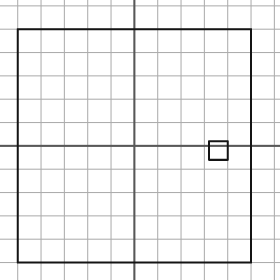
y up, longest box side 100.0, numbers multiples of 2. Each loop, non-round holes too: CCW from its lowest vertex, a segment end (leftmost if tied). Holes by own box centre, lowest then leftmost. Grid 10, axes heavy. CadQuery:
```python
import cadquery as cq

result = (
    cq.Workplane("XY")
    .moveTo(-50.0, -50.0)
    .lineTo(50.0, -50.0)
    .lineTo(50.0, 50.0)
    .lineTo(-50.0, 50.0)
    .close()
    .moveTo(32.0, -6.0)
    .lineTo(40.0, -6.0)
    .lineTo(40.0, 2.0)
    .lineTo(32.0, 2.0)
    .close()
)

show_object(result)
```